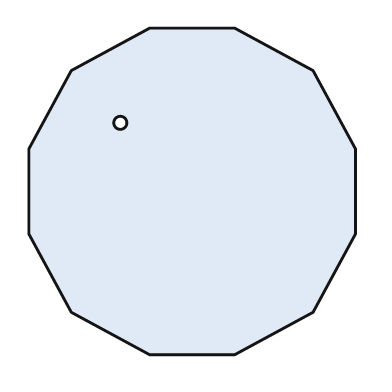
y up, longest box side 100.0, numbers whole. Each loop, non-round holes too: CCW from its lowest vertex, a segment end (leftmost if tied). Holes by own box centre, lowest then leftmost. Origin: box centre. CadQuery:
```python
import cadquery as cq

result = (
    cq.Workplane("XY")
    .moveTo(-13.0, -50.0)
    .lineTo(13.0, -50.0)
    .lineTo(37.0, -37.0)
    .lineTo(50.0, -13.0)
    .lineTo(50.0, 13.0)
    .lineTo(37.0, 37.0)
    .lineTo(13.0, 50.0)
    .lineTo(-13.0, 50.0)
    .lineTo(-37.0, 37.0)
    .lineTo(-50.0, 13.0)
    .lineTo(-50.0, -13.0)
    .lineTo(-37.0, -37.0)
    .close()
    .moveTo(-22.0, 21.0)
    .circle(2.0)
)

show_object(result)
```